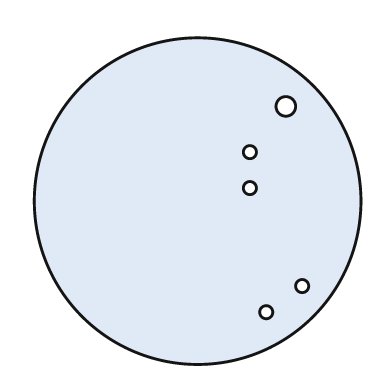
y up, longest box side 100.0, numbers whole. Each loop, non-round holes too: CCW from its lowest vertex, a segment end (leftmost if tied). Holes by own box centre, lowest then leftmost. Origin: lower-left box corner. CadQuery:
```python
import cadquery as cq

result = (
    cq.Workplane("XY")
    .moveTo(50.0, 50.0)
    .circle(50.0)
    .moveTo(71.0, 16.0)
    .circle(2.0)
    .moveTo(82.0, 24.0)
    .circle(2.0)
    .moveTo(66.0, 54.0)
    .circle(2.0)
    .moveTo(66.0, 65.0)
    .circle(2.0)
    .moveTo(77.0, 79.0)
    .circle(3.0)
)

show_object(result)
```